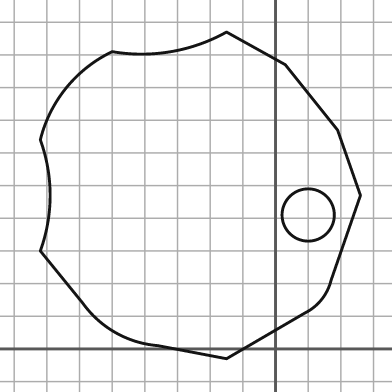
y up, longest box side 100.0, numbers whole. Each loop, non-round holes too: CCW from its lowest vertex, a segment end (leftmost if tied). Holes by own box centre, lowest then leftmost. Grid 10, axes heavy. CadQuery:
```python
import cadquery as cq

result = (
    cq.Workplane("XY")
    .moveTo(-15.0, -3.0)
    .lineTo(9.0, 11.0)
    .threePointArc((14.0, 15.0), (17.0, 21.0))
    .lineTo(26.0, 47.0)
    .lineTo(19.0, 67.0)
    .lineTo(3.0, 87.0)
    .lineTo(-15.0, 97.0)
    .threePointArc((-32.0, 91.0), (-50.0, 91.0))
    .threePointArc((-64.0, 80.0), (-72.0, 64.0))
    .threePointArc((-69.0, 47.0), (-72.0, 30.0))
    .lineTo(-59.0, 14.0)
    .threePointArc((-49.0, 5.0), (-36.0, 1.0))
    .close()
    .moveTo(10.0, 41.0)
    .circle(8.0)
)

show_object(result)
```